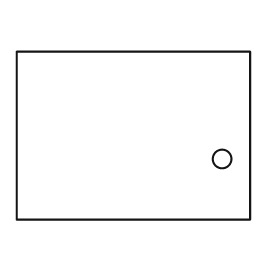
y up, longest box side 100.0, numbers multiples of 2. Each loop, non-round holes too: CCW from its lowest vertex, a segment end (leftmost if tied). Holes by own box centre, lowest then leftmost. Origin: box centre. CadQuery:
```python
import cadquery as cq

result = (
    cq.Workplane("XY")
    .moveTo(-50.0, -36.0)
    .lineTo(50.0, -36.0)
    .lineTo(50.0, 36.0)
    .lineTo(-50.0, 36.0)
    .close()
    .moveTo(38.0, -10.0)
    .circle(4.0)
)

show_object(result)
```